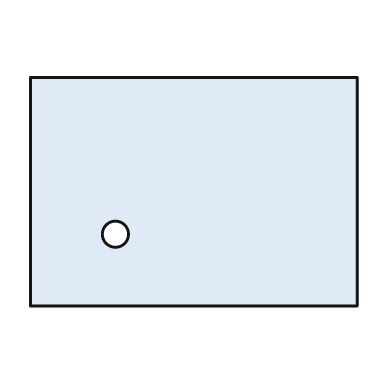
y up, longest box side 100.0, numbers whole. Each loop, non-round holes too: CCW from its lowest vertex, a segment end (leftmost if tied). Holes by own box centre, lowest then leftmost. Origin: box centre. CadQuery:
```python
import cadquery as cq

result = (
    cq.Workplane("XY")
    .moveTo(-50.0, -35.0)
    .lineTo(50.0, -35.0)
    .lineTo(50.0, 35.0)
    .lineTo(-50.0, 35.0)
    .close()
    .moveTo(-24.0, -13.0)
    .circle(4.0)
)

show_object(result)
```